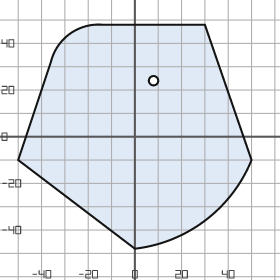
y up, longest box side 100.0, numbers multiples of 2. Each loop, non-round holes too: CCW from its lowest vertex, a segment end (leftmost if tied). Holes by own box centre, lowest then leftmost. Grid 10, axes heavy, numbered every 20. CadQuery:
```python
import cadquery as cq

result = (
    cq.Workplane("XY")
    .moveTo(0.0, -48.0)
    .threePointArc((30.0, -36.0), (50.0, -10.0))
    .lineTo(30.0, 48.0)
    .lineTo(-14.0, 48.0)
    .threePointArc((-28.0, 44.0), (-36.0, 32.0))
    .lineTo(-50.0, -10.0)
    .close()
    .moveTo(8.0, 24.0)
    .circle(2.0)
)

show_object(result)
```